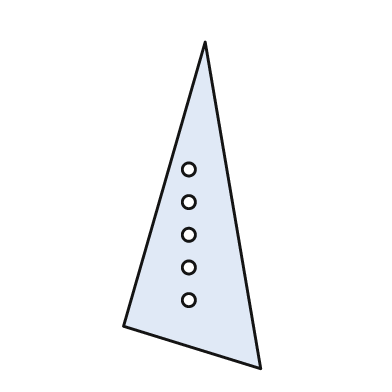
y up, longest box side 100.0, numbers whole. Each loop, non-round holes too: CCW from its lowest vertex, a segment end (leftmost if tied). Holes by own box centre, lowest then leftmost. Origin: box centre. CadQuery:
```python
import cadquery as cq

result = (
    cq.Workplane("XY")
    .moveTo(21.0, -50.0)
    .lineTo(4.0, 50.0)
    .lineTo(-21.0, -37.0)
    .close()
    .moveTo(-1.0, -29.0)
    .circle(2.0)
    .moveTo(-1.0, -19.0)
    .circle(2.0)
    .moveTo(-1.0, -9.0)
    .circle(2.0)
    .moveTo(-1.0, 1.0)
    .circle(2.0)
    .moveTo(-1.0, 11.0)
    .circle(2.0)
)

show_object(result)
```